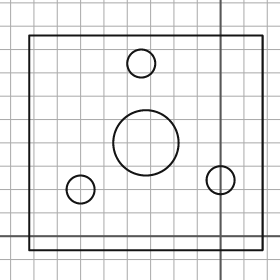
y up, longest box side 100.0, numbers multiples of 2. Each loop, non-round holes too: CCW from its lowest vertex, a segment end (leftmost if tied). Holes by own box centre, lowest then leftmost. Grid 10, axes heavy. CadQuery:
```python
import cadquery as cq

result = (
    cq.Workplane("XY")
    .moveTo(-82.0, -6.0)
    .lineTo(18.0, -6.0)
    .lineTo(18.0, 86.0)
    .lineTo(-82.0, 86.0)
    .close()
    .moveTo(-60.0, 20.0)
    .circle(6.0)
    .moveTo(0.0, 24.0)
    .circle(6.0)
    .moveTo(-32.0, 40.0)
    .circle(14.0)
    .moveTo(-34.0, 74.0)
    .circle(6.0)
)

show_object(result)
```